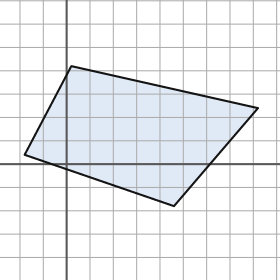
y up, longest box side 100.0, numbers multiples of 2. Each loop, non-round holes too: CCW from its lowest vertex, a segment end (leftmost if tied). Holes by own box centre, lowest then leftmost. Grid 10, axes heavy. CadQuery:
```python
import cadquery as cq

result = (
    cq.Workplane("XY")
    .moveTo(46.0, -18.0)
    .lineTo(82.0, 24.0)
    .lineTo(2.0, 42.0)
    .lineTo(-18.0, 4.0)
    .close()
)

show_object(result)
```